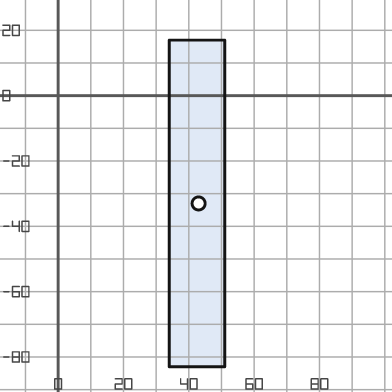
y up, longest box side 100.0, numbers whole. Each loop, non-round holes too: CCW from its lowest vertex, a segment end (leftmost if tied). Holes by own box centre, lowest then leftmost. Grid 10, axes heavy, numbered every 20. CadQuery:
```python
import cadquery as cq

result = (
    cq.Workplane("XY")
    .moveTo(34.0, -83.0)
    .lineTo(51.0, -83.0)
    .lineTo(51.0, 17.0)
    .lineTo(34.0, 17.0)
    .close()
    .moveTo(43.0, -33.0)
    .circle(2.0)
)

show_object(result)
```